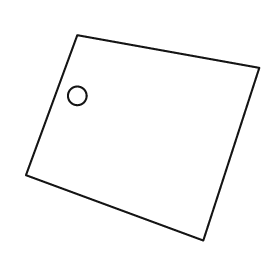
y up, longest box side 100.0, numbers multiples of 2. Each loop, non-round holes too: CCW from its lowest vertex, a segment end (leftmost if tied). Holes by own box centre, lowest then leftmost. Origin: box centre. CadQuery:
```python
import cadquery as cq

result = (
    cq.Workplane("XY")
    .moveTo(26.0, -44.0)
    .lineTo(50.0, 30.0)
    .lineTo(-28.0, 44.0)
    .lineTo(-50.0, -16.0)
    .close()
    .moveTo(-28.0, 18.0)
    .circle(4.0)
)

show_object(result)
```